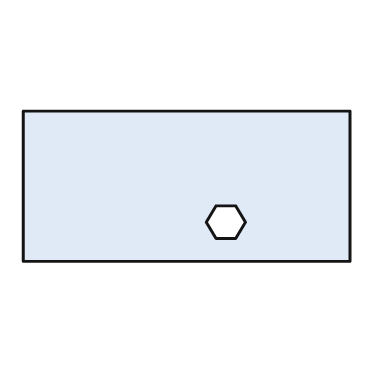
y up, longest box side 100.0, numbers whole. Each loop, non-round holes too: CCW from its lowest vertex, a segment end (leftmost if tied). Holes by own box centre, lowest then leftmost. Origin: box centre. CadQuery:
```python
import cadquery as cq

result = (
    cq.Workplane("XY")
    .moveTo(-50.0, -23.0)
    .lineTo(50.0, -23.0)
    .lineTo(50.0, 23.0)
    .lineTo(-50.0, 23.0)
    .close()
    .moveTo(9.0, -16.0)
    .lineTo(15.0, -16.0)
    .lineTo(18.0, -11.0)
    .lineTo(15.0, -6.0)
    .lineTo(9.0, -6.0)
    .lineTo(6.0, -11.0)
    .close()
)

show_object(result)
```